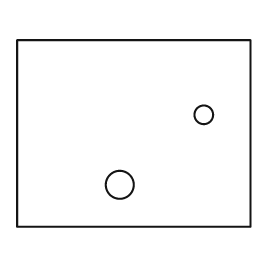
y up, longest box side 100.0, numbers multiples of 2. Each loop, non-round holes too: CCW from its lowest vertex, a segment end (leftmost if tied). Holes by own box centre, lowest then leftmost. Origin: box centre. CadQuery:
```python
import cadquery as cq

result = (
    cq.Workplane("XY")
    .moveTo(-50.0, -40.0)
    .lineTo(50.0, -40.0)
    .lineTo(50.0, 40.0)
    .lineTo(-50.0, 40.0)
    .close()
    .moveTo(-6.0, -22.0)
    .circle(6.0)
    .moveTo(30.0, 8.0)
    .circle(4.0)
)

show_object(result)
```